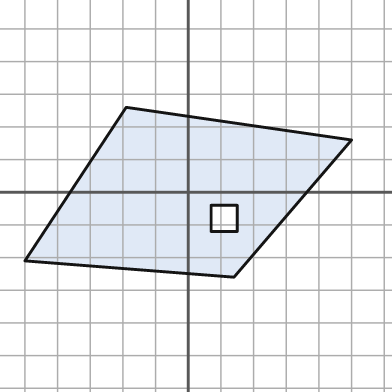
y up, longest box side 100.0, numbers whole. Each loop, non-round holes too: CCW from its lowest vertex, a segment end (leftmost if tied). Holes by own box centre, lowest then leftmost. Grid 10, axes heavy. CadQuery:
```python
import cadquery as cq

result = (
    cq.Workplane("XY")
    .moveTo(14.0, -26.0)
    .lineTo(50.0, 16.0)
    .lineTo(-19.0, 26.0)
    .lineTo(-50.0, -21.0)
    .close()
    .moveTo(7.0, -12.0)
    .lineTo(15.0, -12.0)
    .lineTo(15.0, -4.0)
    .lineTo(7.0, -4.0)
    .close()
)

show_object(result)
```